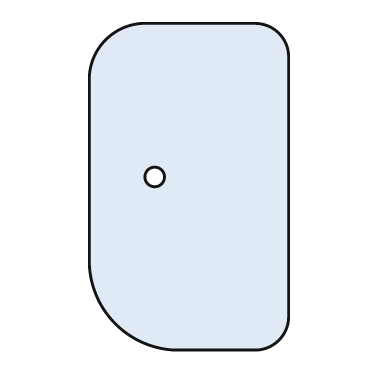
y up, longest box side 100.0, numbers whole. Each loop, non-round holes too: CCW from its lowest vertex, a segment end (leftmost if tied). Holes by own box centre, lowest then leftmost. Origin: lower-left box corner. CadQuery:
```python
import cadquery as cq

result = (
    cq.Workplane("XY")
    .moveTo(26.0, 0.0)
    .lineTo(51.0, 0.0)
    .threePointArc((58.0, 3.0), (61.0, 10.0))
    .lineTo(61.0, 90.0)
    .threePointArc((58.0, 97.0), (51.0, 100.0))
    .lineTo(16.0, 100.0)
    .threePointArc((5.0, 95.0), (0.0, 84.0))
    .lineTo(0.0, 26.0)
    .threePointArc((8.0, 8.0), (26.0, 0.0))
    .close()
    .moveTo(20.0, 53.0)
    .circle(3.0)
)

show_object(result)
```